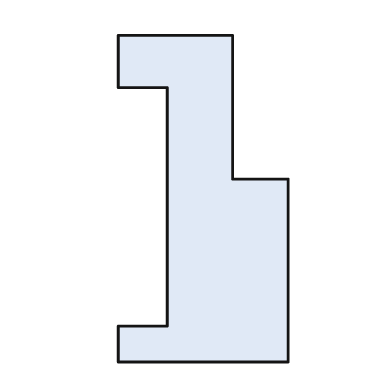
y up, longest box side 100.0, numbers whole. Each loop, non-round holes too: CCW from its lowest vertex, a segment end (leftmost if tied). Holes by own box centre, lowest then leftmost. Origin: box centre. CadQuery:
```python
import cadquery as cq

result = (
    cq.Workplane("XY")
    .moveTo(-26.0, -50.0)
    .lineTo(26.0, -50.0)
    .lineTo(26.0, 6.0)
    .lineTo(9.0, 6.0)
    .lineTo(9.0, 50.0)
    .lineTo(-26.0, 50.0)
    .lineTo(-26.0, 34.0)
    .lineTo(-11.0, 34.0)
    .lineTo(-11.0, -39.0)
    .lineTo(-26.0, -39.0)
    .close()
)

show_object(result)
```